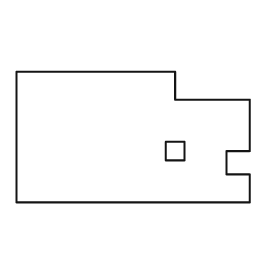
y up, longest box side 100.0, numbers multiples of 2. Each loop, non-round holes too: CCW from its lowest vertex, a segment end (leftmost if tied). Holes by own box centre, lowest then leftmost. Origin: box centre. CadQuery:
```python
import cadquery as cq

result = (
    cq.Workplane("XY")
    .moveTo(-50.0, -28.0)
    .lineTo(50.0, -28.0)
    .lineTo(50.0, -16.0)
    .lineTo(40.0, -16.0)
    .lineTo(40.0, -6.0)
    .lineTo(50.0, -6.0)
    .lineTo(50.0, 16.0)
    .lineTo(18.0, 16.0)
    .lineTo(18.0, 28.0)
    .lineTo(-50.0, 28.0)
    .close()
    .moveTo(14.0, -10.0)
    .lineTo(22.0, -10.0)
    .lineTo(22.0, -2.0)
    .lineTo(14.0, -2.0)
    .close()
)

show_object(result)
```